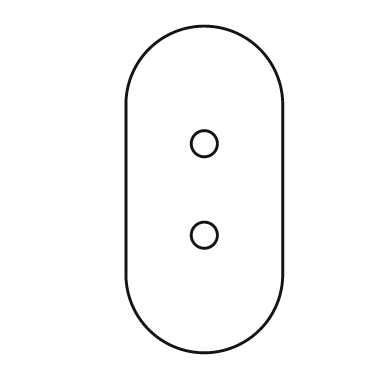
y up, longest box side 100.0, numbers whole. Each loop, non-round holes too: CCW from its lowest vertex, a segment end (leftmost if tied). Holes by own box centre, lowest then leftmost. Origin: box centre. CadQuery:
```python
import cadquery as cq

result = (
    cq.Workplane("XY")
    .moveTo(-24.0, -26.0)
    .threePointArc((0.0, -50.0), (24.0, -26.0))
    .lineTo(24.0, 26.0)
    .threePointArc((0.0, 50.0), (-24.0, 26.0))
    .close()
    .moveTo(0.0, -14.0)
    .circle(4.0)
    .moveTo(0.0, 14.0)
    .circle(4.0)
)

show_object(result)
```